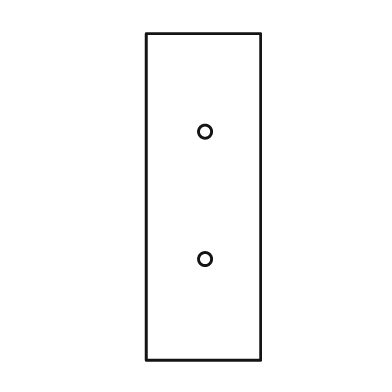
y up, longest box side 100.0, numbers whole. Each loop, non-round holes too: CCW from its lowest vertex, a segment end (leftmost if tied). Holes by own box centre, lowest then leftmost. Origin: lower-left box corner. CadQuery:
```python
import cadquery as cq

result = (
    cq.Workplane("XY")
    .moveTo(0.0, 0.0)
    .lineTo(35.0, 0.0)
    .lineTo(35.0, 100.0)
    .lineTo(0.0, 100.0)
    .close()
    .moveTo(18.0, 31.0)
    .circle(2.0)
    .moveTo(18.0, 70.0)
    .circle(2.0)
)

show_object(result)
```